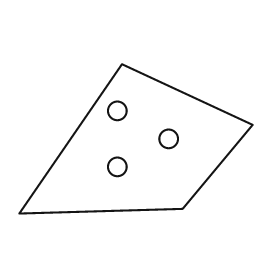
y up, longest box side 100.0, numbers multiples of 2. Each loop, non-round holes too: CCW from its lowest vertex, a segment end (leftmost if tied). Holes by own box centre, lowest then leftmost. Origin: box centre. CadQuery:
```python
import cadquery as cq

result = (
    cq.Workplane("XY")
    .moveTo(-50.0, -32.0)
    .lineTo(20.0, -30.0)
    .lineTo(50.0, 6.0)
    .lineTo(-6.0, 32.0)
    .close()
    .moveTo(-8.0, -12.0)
    .circle(4.0)
    .moveTo(14.0, 0.0)
    .circle(4.0)
    .moveTo(-8.0, 12.0)
    .circle(4.0)
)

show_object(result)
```